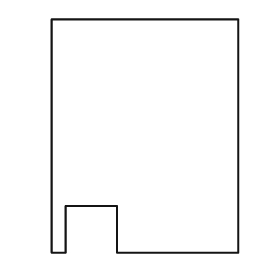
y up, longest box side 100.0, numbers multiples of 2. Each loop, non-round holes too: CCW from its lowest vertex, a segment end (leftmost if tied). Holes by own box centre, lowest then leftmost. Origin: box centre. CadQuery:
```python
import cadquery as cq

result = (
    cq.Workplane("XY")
    .moveTo(-40.0, -50.0)
    .lineTo(-34.0, -50.0)
    .lineTo(-34.0, -30.0)
    .lineTo(-12.0, -30.0)
    .lineTo(-12.0, -50.0)
    .lineTo(40.0, -50.0)
    .lineTo(40.0, 50.0)
    .lineTo(-40.0, 50.0)
    .close()
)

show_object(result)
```